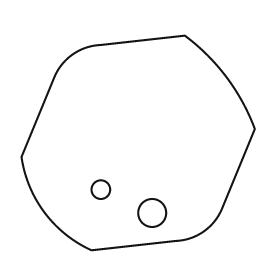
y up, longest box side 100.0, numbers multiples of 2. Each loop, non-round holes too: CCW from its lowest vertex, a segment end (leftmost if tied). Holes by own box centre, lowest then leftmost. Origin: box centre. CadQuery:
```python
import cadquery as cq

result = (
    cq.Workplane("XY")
    .moveTo(-20.0, -46.0)
    .lineTo(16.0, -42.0)
    .threePointArc((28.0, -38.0), (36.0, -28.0))
    .lineTo(50.0, 6.0)
    .threePointArc((38.0, 28.0), (20.0, 46.0))
    .lineTo(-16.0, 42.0)
    .threePointArc((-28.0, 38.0), (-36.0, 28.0))
    .lineTo(-50.0, -6.0)
    .threePointArc((-40.0, -30.0), (-20.0, -46.0))
    .close()
    .moveTo(6.0, -30.0)
    .circle(6.0)
    .moveTo(-16.0, -20.0)
    .circle(4.0)
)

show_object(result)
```